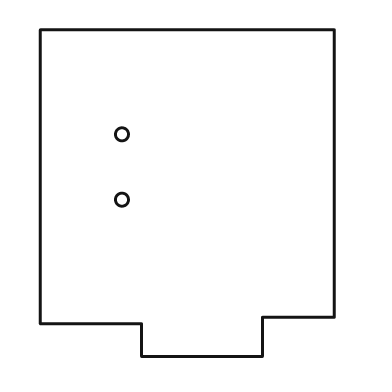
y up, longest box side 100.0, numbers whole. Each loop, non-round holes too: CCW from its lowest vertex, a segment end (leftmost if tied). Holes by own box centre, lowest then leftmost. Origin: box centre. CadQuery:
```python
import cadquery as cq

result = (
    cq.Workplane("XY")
    .moveTo(-14.0, -50.0)
    .lineTo(23.0, -50.0)
    .lineTo(23.0, -38.0)
    .lineTo(45.0, -38.0)
    .lineTo(45.0, 50.0)
    .lineTo(-45.0, 50.0)
    .lineTo(-45.0, -40.0)
    .lineTo(-14.0, -40.0)
    .close()
    .moveTo(-20.0, -2.0)
    .circle(2.0)
    .moveTo(-20.0, 18.0)
    .circle(2.0)
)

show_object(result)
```